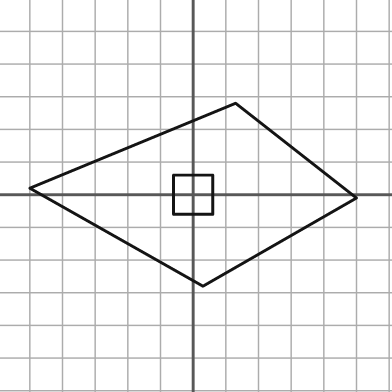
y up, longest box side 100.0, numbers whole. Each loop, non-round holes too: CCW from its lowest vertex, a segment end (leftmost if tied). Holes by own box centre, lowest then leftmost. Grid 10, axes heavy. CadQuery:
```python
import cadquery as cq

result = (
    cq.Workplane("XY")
    .moveTo(3.0, -28.0)
    .lineTo(50.0, -1.0)
    .lineTo(13.0, 28.0)
    .lineTo(-50.0, 2.0)
    .close()
    .moveTo(-6.0, -6.0)
    .lineTo(6.0, -6.0)
    .lineTo(6.0, 6.0)
    .lineTo(-6.0, 6.0)
    .close()
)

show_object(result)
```